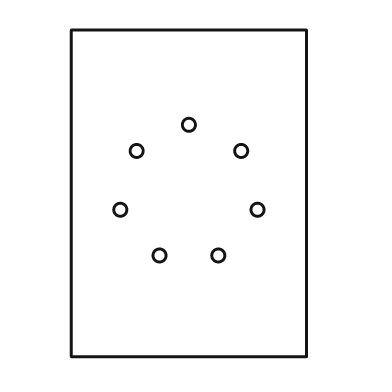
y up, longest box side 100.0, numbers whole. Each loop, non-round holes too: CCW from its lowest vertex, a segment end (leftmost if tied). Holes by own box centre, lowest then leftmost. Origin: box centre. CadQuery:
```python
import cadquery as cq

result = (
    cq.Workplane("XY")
    .moveTo(-36.0, -50.0)
    .lineTo(36.0, -50.0)
    .lineTo(36.0, 50.0)
    .lineTo(-36.0, 50.0)
    .close()
    .moveTo(-9.0, -19.0)
    .circle(2.0)
    .moveTo(9.0, -19.0)
    .circle(2.0)
    .moveTo(-21.0, -5.0)
    .circle(2.0)
    .moveTo(21.0, -5.0)
    .circle(2.0)
    .moveTo(-16.0, 13.0)
    .circle(2.0)
    .moveTo(16.0, 13.0)
    .circle(2.0)
    .moveTo(0.0, 21.0)
    .circle(2.0)
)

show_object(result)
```